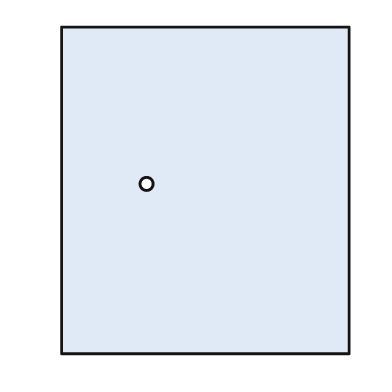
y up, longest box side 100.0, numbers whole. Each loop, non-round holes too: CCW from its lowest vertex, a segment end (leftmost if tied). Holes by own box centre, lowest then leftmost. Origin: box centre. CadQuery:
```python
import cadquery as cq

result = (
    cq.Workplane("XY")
    .moveTo(-44.0, -50.0)
    .lineTo(44.0, -50.0)
    .lineTo(44.0, 50.0)
    .lineTo(-44.0, 50.0)
    .close()
    .moveTo(-18.0, 2.0)
    .circle(2.0)
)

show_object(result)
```